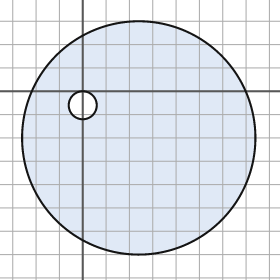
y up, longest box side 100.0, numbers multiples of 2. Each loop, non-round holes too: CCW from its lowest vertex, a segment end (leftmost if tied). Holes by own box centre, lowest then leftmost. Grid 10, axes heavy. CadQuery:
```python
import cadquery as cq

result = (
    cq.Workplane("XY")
    .moveTo(24.0, -20.0)
    .circle(50.0)
    .moveTo(0.0, -6.0)
    .circle(6.0)
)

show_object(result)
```